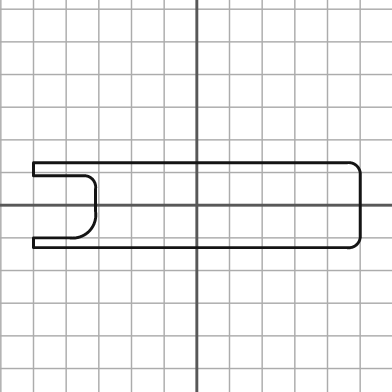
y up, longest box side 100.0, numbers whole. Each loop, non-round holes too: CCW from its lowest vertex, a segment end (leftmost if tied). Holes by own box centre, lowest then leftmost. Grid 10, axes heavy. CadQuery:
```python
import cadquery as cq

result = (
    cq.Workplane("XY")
    .moveTo(-50.0, -13.0)
    .lineTo(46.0, -13.0)
    .threePointArc((49.0, -12.0), (50.0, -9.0))
    .lineTo(50.0, 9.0)
    .threePointArc((49.0, 12.0), (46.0, 13.0))
    .lineTo(-50.0, 13.0)
    .lineTo(-50.0, 9.0)
    .lineTo(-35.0, 9.0)
    .threePointArc((-32.0, 8.0), (-31.0, 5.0))
    .lineTo(-31.0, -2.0)
    .threePointArc((-33.0, -8.0), (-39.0, -10.0))
    .lineTo(-50.0, -10.0)
    .close()
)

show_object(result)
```